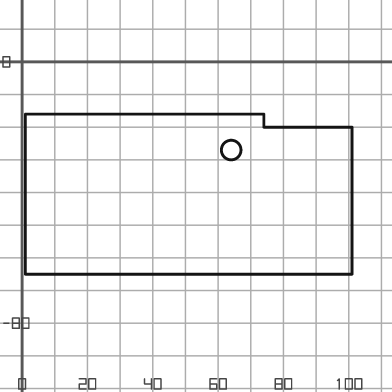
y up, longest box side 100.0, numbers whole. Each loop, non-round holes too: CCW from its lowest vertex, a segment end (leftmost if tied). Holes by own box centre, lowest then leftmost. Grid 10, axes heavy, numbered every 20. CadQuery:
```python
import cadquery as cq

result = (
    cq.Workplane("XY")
    .moveTo(1.0, -65.0)
    .lineTo(101.0, -65.0)
    .lineTo(101.0, -20.0)
    .lineTo(74.0, -20.0)
    .lineTo(74.0, -16.0)
    .lineTo(1.0, -16.0)
    .close()
    .moveTo(64.0, -27.0)
    .circle(3.0)
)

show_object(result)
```